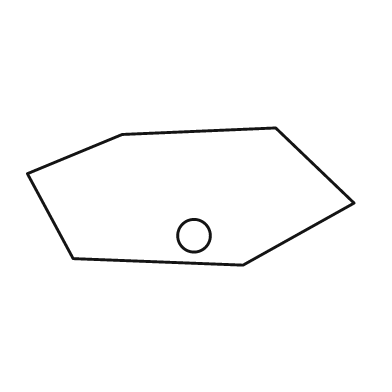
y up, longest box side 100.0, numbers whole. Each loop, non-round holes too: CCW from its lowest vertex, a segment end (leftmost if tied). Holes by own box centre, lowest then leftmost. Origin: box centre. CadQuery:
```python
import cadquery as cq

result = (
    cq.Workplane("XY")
    .moveTo(16.0, -21.0)
    .lineTo(50.0, -2.0)
    .lineTo(26.0, 21.0)
    .lineTo(-21.0, 19.0)
    .lineTo(-50.0, 7.0)
    .lineTo(-36.0, -19.0)
    .close()
    .moveTo(1.0, -12.0)
    .circle(5.0)
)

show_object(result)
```